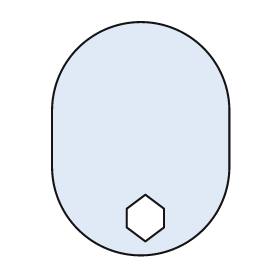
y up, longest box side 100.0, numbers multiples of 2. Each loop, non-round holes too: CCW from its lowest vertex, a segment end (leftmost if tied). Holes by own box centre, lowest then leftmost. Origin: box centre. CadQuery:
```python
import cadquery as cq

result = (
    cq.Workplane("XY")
    .moveTo(-38.0, -12.0)
    .threePointArc((0.0, -50.0), (38.0, -12.0))
    .lineTo(38.0, 12.0)
    .threePointArc((0.0, 50.0), (-38.0, 12.0))
    .close()
    .moveTo(2.0, -44.0)
    .lineTo(10.0, -38.0)
    .lineTo(10.0, -30.0)
    .lineTo(2.0, -24.0)
    .lineTo(-6.0, -30.0)
    .lineTo(-6.0, -38.0)
    .close()
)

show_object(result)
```